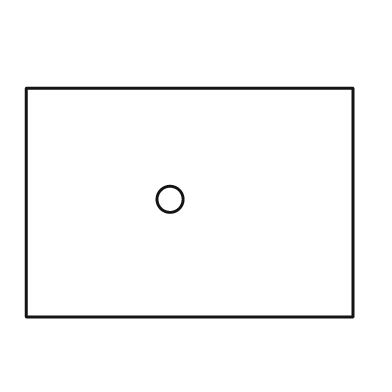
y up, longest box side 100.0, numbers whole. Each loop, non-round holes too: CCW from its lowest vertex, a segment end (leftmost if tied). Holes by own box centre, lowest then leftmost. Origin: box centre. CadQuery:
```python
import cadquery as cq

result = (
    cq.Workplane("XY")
    .moveTo(-50.0, -35.0)
    .lineTo(50.0, -35.0)
    .lineTo(50.0, 35.0)
    .lineTo(-50.0, 35.0)
    .close()
    .moveTo(-6.0, 1.0)
    .circle(4.0)
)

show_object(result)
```